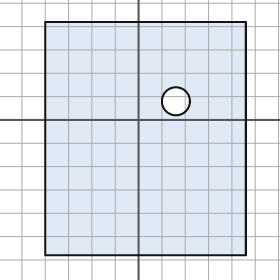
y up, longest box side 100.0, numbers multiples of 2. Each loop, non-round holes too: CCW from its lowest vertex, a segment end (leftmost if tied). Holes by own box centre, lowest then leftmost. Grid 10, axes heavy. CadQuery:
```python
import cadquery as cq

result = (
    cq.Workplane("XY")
    .moveTo(-40.0, -58.0)
    .lineTo(46.0, -58.0)
    .lineTo(46.0, 42.0)
    .lineTo(-40.0, 42.0)
    .close()
    .moveTo(16.0, 8.0)
    .circle(6.0)
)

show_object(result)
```